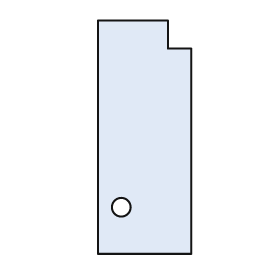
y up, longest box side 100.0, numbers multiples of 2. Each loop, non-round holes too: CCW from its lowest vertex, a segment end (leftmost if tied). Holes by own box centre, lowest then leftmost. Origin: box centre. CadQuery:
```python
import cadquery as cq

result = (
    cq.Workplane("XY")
    .moveTo(-20.0, -50.0)
    .lineTo(20.0, -50.0)
    .lineTo(20.0, 38.0)
    .lineTo(10.0, 38.0)
    .lineTo(10.0, 50.0)
    .lineTo(-20.0, 50.0)
    .close()
    .moveTo(-10.0, -30.0)
    .circle(4.0)
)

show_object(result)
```